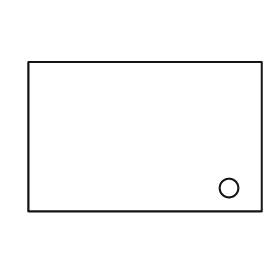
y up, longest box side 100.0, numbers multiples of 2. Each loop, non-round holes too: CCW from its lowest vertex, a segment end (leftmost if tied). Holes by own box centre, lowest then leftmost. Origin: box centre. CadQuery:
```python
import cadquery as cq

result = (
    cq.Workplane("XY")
    .moveTo(-50.0, -32.0)
    .lineTo(50.0, -32.0)
    .lineTo(50.0, 32.0)
    .lineTo(-50.0, 32.0)
    .close()
    .moveTo(36.0, -22.0)
    .circle(4.0)
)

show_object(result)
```